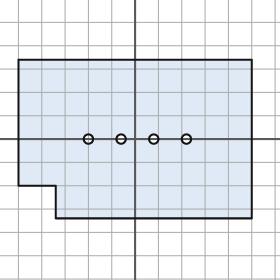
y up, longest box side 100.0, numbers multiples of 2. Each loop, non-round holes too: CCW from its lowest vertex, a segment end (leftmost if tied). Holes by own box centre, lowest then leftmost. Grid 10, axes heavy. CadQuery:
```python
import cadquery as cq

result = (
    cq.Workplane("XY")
    .moveTo(-34.0, -34.0)
    .lineTo(50.0, -34.0)
    .lineTo(50.0, 34.0)
    .lineTo(-50.0, 34.0)
    .lineTo(-50.0, -20.0)
    .lineTo(-34.0, -20.0)
    .close()
    .moveTo(-20.0, 0.0)
    .circle(2.0)
    .moveTo(-6.0, 0.0)
    .circle(2.0)
    .moveTo(8.0, 0.0)
    .circle(2.0)
    .moveTo(22.0, 0.0)
    .circle(2.0)
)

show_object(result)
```